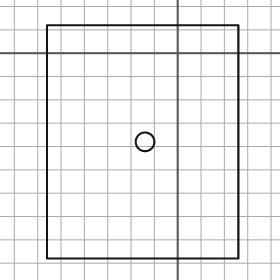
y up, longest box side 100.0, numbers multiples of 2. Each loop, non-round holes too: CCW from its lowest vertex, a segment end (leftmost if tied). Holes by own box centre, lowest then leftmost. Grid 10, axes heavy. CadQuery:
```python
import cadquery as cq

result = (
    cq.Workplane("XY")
    .moveTo(-56.0, -88.0)
    .lineTo(26.0, -88.0)
    .lineTo(26.0, 12.0)
    .lineTo(-56.0, 12.0)
    .close()
    .moveTo(-14.0, -38.0)
    .circle(4.0)
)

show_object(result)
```